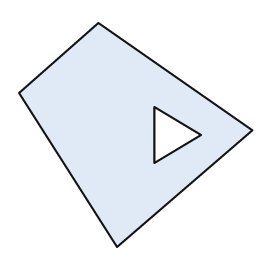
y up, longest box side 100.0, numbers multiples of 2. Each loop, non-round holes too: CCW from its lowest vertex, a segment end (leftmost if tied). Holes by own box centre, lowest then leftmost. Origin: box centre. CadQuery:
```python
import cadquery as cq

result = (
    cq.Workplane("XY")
    .moveTo(-8.0, -48.0)
    .lineTo(50.0, 2.0)
    .lineTo(-16.0, 48.0)
    .lineTo(-50.0, 18.0)
    .close()
    .moveTo(8.0, -12.0)
    .lineTo(28.0, 0.0)
    .lineTo(8.0, 12.0)
    .close()
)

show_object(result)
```